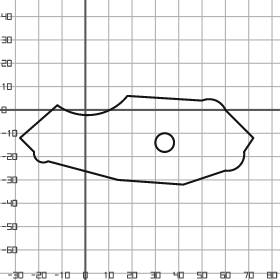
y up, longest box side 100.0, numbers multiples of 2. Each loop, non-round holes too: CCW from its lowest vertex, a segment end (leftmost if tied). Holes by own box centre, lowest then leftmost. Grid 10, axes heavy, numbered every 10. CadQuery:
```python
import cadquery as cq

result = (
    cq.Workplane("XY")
    .moveTo(42.0, -32.0)
    .lineTo(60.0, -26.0)
    .threePointArc((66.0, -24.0), (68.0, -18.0))
    .lineTo(72.0, -12.0)
    .lineTo(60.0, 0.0)
    .threePointArc((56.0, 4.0), (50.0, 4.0))
    .lineTo(18.0, 6.0)
    .threePointArc((4.0, -2.0), (-12.0, 2.0))
    .lineTo(-28.0, -12.0)
    .lineTo(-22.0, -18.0)
    .threePointArc((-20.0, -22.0), (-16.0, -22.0))
    .lineTo(14.0, -30.0)
    .close()
    .moveTo(34.0, -14.0)
    .circle(4.0)
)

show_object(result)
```